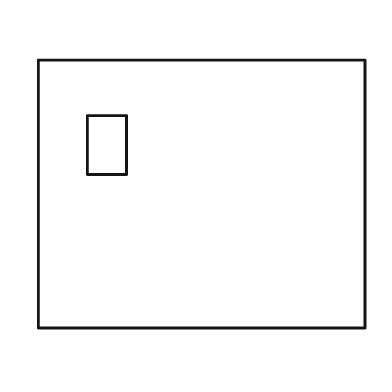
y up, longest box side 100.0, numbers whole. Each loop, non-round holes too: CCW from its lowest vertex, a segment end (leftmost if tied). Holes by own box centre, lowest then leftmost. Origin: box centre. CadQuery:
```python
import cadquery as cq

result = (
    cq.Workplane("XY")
    .moveTo(-50.0, -41.0)
    .lineTo(50.0, -41.0)
    .lineTo(50.0, 41.0)
    .lineTo(-50.0, 41.0)
    .close()
    .moveTo(-35.0, 6.0)
    .lineTo(-23.0, 6.0)
    .lineTo(-23.0, 24.0)
    .lineTo(-35.0, 24.0)
    .close()
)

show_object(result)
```